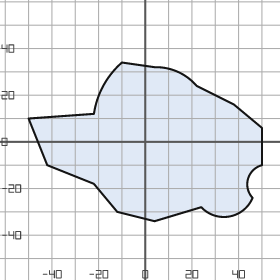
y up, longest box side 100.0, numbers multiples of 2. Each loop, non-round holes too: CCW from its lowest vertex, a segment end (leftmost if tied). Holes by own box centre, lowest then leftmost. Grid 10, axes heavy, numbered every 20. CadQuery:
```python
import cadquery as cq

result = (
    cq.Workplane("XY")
    .moveTo(4.0, -34.0)
    .lineTo(24.0, -28.0)
    .threePointArc((36.0, -32.0), (46.0, -24.0))
    .threePointArc((44.0, -16.0), (50.0, -10.0))
    .lineTo(50.0, 6.0)
    .lineTo(38.0, 16.0)
    .lineTo(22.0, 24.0)
    .threePointArc((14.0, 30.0), (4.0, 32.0))
    .lineTo(-10.0, 34.0)
    .threePointArc((-18.0, 24.0), (-22.0, 12.0))
    .lineTo(-50.0, 10.0)
    .lineTo(-42.0, -10.0)
    .lineTo(-22.0, -18.0)
    .lineTo(-12.0, -30.0)
    .close()
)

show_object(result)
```